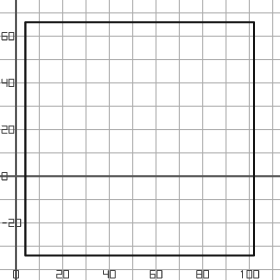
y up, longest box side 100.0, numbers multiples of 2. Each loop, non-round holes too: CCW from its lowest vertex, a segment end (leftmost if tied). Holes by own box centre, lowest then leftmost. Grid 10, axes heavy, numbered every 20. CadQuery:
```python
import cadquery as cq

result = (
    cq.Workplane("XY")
    .moveTo(4.0, -34.0)
    .lineTo(102.0, -34.0)
    .lineTo(102.0, 66.0)
    .lineTo(4.0, 66.0)
    .close()
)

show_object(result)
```